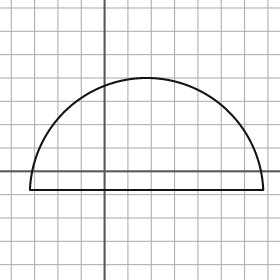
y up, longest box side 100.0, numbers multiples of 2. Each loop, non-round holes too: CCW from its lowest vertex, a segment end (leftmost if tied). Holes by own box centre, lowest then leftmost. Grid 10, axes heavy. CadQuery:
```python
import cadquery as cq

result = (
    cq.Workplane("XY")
    .moveTo(-32.0, -8.0)
    .lineTo(68.0, -8.0)
    .threePointArc((18.0, 40.0), (-32.0, -8.0))
    .close()
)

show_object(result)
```